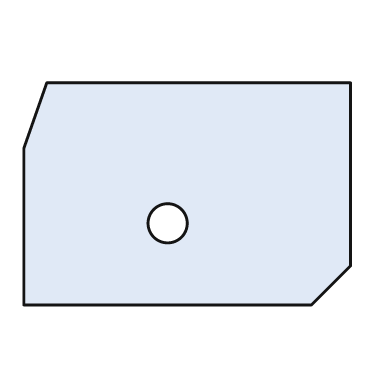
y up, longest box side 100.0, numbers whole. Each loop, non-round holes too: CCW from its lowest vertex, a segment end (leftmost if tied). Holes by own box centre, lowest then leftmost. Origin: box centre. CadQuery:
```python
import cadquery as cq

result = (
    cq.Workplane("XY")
    .moveTo(-50.0, -34.0)
    .lineTo(38.0, -34.0)
    .lineTo(50.0, -22.0)
    .lineTo(50.0, 34.0)
    .lineTo(-43.0, 34.0)
    .lineTo(-50.0, 14.0)
    .close()
    .moveTo(-6.0, -9.0)
    .circle(6.0)
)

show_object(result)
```